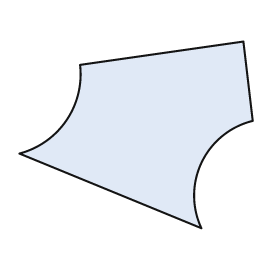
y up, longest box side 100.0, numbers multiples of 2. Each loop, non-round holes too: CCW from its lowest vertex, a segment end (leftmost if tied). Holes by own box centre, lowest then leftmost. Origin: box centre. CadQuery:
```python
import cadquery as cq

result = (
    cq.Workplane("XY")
    .moveTo(28.0, -40.0)
    .threePointArc((28.0, -12.0), (50.0, 6.0))
    .lineTo(46.0, 40.0)
    .lineTo(-24.0, 30.0)
    .threePointArc((-30.0, 6.0), (-50.0, -8.0))
    .close()
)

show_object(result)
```